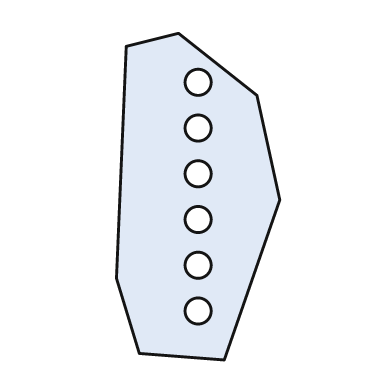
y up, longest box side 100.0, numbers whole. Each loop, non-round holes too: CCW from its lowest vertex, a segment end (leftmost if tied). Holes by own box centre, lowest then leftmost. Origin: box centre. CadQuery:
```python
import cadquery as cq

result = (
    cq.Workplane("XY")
    .moveTo(8.0, -50.0)
    .lineTo(25.0, -1.0)
    .lineTo(18.0, 31.0)
    .lineTo(-6.0, 50.0)
    .lineTo(-22.0, 46.0)
    .lineTo(-25.0, -25.0)
    .lineTo(-18.0, -48.0)
    .close()
    .moveTo(0.0, -35.0)
    .circle(4.0)
    .moveTo(0.0, -21.0)
    .circle(4.0)
    .moveTo(0.0, -7.0)
    .circle(4.0)
    .moveTo(0.0, 7.0)
    .circle(4.0)
    .moveTo(0.0, 21.0)
    .circle(4.0)
    .moveTo(0.0, 35.0)
    .circle(4.0)
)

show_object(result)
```